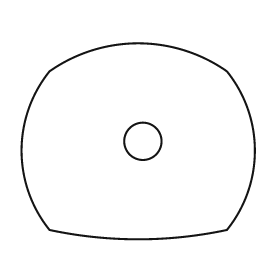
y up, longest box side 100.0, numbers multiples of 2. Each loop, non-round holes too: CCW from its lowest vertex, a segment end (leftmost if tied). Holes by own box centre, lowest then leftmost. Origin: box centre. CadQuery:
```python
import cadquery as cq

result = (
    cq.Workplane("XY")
    .moveTo(-38.0, -38.0)
    .threePointArc((0.0, -42.0), (38.0, -38.0))
    .threePointArc((50.0, -4.0), (38.0, 30.0))
    .threePointArc((0.0, 42.0), (-38.0, 30.0))
    .threePointArc((-50.0, -4.0), (-38.0, -38.0))
    .close()
    .moveTo(2.0, 0.0)
    .circle(8.0)
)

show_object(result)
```